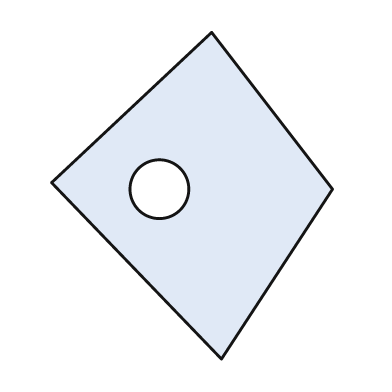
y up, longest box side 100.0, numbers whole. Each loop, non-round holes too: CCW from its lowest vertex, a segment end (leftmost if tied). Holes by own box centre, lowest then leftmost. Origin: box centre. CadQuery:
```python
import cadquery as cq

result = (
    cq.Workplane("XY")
    .moveTo(9.0, -50.0)
    .lineTo(43.0, 2.0)
    .lineTo(6.0, 50.0)
    .lineTo(-43.0, 4.0)
    .close()
    .moveTo(-10.0, 2.0)
    .circle(9.0)
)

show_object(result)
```